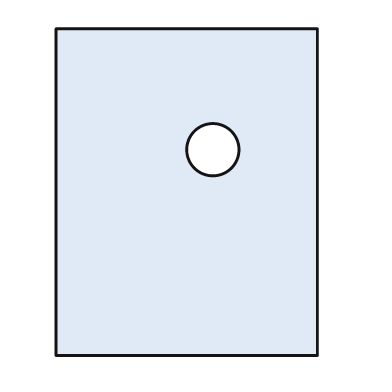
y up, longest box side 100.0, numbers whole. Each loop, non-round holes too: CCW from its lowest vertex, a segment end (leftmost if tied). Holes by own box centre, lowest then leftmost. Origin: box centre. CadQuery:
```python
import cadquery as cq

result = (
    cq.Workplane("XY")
    .moveTo(-40.0, -50.0)
    .lineTo(40.0, -50.0)
    .lineTo(40.0, 50.0)
    .lineTo(-40.0, 50.0)
    .close()
    .moveTo(8.0, 13.0)
    .circle(8.0)
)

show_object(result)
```